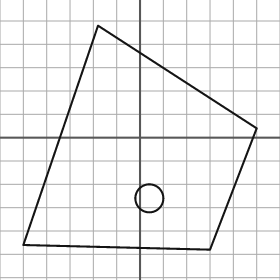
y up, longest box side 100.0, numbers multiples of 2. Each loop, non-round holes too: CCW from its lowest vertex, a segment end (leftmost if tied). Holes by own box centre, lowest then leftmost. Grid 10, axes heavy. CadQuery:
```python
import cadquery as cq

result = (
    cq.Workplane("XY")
    .moveTo(30.0, -48.0)
    .lineTo(50.0, 4.0)
    .lineTo(-18.0, 48.0)
    .lineTo(-50.0, -46.0)
    .close()
    .moveTo(4.0, -26.0)
    .circle(6.0)
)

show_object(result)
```